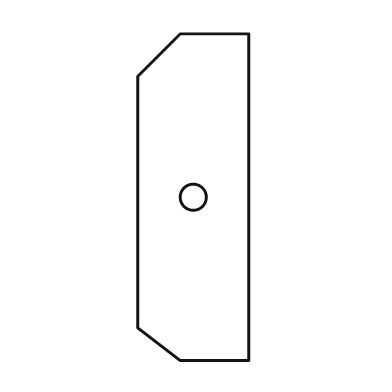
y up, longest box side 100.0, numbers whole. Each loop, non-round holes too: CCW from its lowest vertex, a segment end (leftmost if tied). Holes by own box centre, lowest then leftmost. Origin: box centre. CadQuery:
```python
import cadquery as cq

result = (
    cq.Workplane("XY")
    .moveTo(-4.0, -50.0)
    .lineTo(17.0, -50.0)
    .lineTo(17.0, 50.0)
    .lineTo(-4.0, 50.0)
    .lineTo(-17.0, 37.0)
    .lineTo(-17.0, -40.0)
    .close()
    .moveTo(0.0, 0.0)
    .circle(4.0)
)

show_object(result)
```